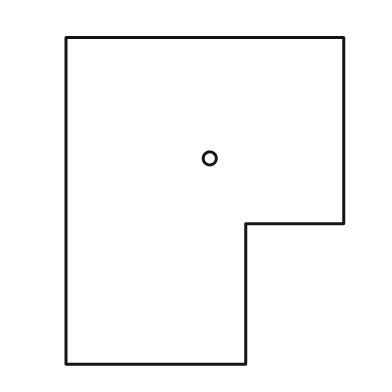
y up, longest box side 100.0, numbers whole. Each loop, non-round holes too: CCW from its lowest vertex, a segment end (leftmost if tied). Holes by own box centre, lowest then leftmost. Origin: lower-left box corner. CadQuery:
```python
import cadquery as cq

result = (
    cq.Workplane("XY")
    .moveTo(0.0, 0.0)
    .lineTo(55.0, 0.0)
    .lineTo(55.0, 43.0)
    .lineTo(85.0, 43.0)
    .lineTo(85.0, 100.0)
    .lineTo(0.0, 100.0)
    .close()
    .moveTo(44.0, 63.0)
    .circle(2.0)
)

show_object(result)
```